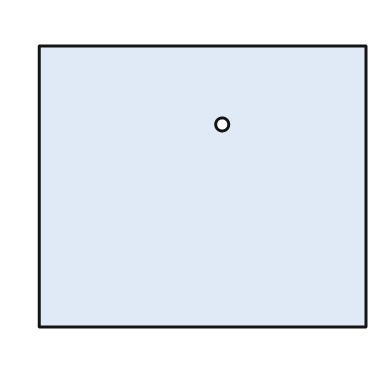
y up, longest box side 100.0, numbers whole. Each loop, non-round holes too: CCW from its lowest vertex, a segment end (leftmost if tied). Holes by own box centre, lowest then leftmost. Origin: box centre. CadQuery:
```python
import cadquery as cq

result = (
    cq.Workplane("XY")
    .moveTo(-50.0, -43.0)
    .lineTo(50.0, -43.0)
    .lineTo(50.0, 43.0)
    .lineTo(-50.0, 43.0)
    .close()
    .moveTo(6.0, 19.0)
    .circle(2.0)
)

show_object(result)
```